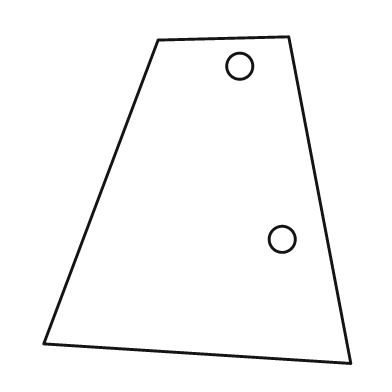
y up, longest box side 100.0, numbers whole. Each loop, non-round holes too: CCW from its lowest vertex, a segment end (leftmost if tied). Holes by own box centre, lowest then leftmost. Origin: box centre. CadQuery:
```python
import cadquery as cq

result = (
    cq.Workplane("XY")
    .moveTo(47.0, -50.0)
    .lineTo(28.0, 50.0)
    .lineTo(-12.0, 49.0)
    .lineTo(-47.0, -44.0)
    .close()
    .moveTo(26.0, -12.0)
    .circle(4.0)
    .moveTo(13.0, 41.0)
    .circle(4.0)
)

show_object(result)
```